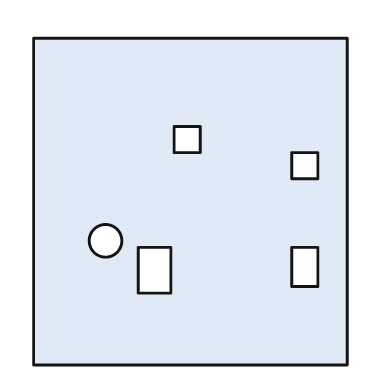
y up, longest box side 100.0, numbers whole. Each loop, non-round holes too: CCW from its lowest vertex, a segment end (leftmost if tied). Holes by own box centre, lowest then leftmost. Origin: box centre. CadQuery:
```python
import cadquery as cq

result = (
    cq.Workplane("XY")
    .moveTo(-48.0, -50.0)
    .lineTo(48.0, -50.0)
    .lineTo(48.0, 50.0)
    .lineTo(-48.0, 50.0)
    .close()
    .moveTo(-16.0, -28.0)
    .lineTo(-6.0, -28.0)
    .lineTo(-6.0, -14.0)
    .lineTo(-16.0, -14.0)
    .close()
    .moveTo(31.0, -26.0)
    .lineTo(39.0, -26.0)
    .lineTo(39.0, -14.0)
    .lineTo(31.0, -14.0)
    .close()
    .moveTo(-26.0, -12.0)
    .circle(5.0)
    .moveTo(31.0, 7.0)
    .lineTo(39.0, 7.0)
    .lineTo(39.0, 15.0)
    .lineTo(31.0, 15.0)
    .close()
    .moveTo(-5.0, 15.0)
    .lineTo(3.0, 15.0)
    .lineTo(3.0, 23.0)
    .lineTo(-5.0, 23.0)
    .close()
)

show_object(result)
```